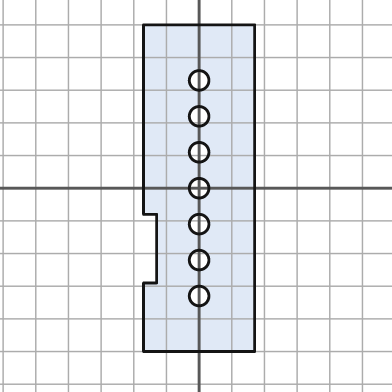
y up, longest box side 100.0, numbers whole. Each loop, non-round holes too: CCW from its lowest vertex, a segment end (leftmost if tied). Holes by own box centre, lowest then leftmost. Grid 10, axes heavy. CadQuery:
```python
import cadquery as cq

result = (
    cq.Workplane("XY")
    .moveTo(-17.0, -50.0)
    .lineTo(17.0, -50.0)
    .lineTo(17.0, 50.0)
    .lineTo(-17.0, 50.0)
    .lineTo(-17.0, -8.0)
    .lineTo(-13.0, -8.0)
    .lineTo(-13.0, -29.0)
    .lineTo(-17.0, -29.0)
    .close()
    .moveTo(0.0, -33.0)
    .circle(3.0)
    .moveTo(0.0, -22.0)
    .circle(3.0)
    .moveTo(0.0, -11.0)
    .circle(3.0)
    .moveTo(0.0, 0.0)
    .circle(3.0)
    .moveTo(0.0, 11.0)
    .circle(3.0)
    .moveTo(0.0, 22.0)
    .circle(3.0)
    .moveTo(0.0, 33.0)
    .circle(3.0)
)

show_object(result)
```